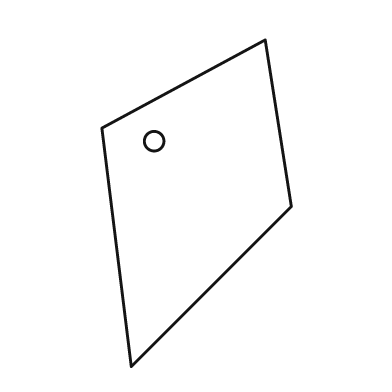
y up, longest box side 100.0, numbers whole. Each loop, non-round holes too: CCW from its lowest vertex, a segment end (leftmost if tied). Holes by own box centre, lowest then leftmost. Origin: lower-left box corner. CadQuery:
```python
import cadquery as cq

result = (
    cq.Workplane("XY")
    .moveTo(9.0, 0.0)
    .lineTo(58.0, 49.0)
    .lineTo(50.0, 100.0)
    .lineTo(0.0, 73.0)
    .close()
    .moveTo(16.0, 69.0)
    .circle(3.0)
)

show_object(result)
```